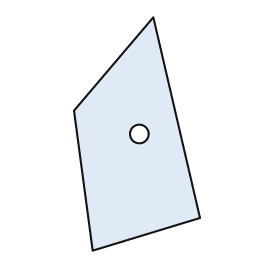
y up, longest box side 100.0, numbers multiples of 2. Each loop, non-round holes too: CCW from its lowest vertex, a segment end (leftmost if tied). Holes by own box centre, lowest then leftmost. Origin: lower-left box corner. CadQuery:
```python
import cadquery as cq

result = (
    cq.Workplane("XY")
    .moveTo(8.0, 0.0)
    .lineTo(54.0, 14.0)
    .lineTo(34.0, 100.0)
    .lineTo(0.0, 60.0)
    .close()
    .moveTo(28.0, 50.0)
    .circle(4.0)
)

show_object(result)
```